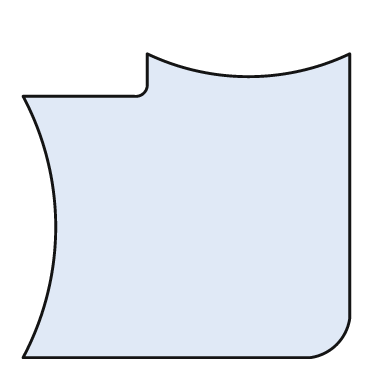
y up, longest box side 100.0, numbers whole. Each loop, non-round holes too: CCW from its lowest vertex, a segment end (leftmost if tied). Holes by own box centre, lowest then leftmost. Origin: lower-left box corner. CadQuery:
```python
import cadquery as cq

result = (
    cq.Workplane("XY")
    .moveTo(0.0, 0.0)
    .lineTo(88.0, 0.0)
    .threePointArc((96.0, 4.0), (100.0, 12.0))
    .lineTo(100.0, 93.0)
    .threePointArc((69.0, 86.0), (38.0, 93.0))
    .lineTo(38.0, 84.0)
    .threePointArc((37.0, 81.0), (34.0, 80.0))
    .lineTo(0.0, 80.0)
    .threePointArc((10.0, 40.0), (0.0, 0.0))
    .close()
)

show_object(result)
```